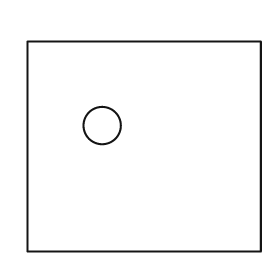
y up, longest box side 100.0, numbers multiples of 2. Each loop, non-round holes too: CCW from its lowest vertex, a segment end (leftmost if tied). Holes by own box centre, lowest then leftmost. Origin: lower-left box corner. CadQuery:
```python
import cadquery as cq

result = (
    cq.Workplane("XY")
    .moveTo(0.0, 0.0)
    .lineTo(100.0, 0.0)
    .lineTo(100.0, 90.0)
    .lineTo(0.0, 90.0)
    .close()
    .moveTo(32.0, 54.0)
    .circle(8.0)
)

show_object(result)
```